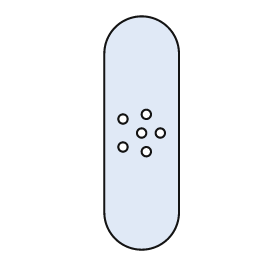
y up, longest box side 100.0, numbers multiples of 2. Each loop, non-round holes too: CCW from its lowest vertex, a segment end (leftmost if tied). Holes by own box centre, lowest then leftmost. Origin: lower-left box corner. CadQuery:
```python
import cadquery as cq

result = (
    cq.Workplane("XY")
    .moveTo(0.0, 16.0)
    .threePointArc((16.0, 0.0), (32.0, 16.0))
    .lineTo(32.0, 84.0)
    .threePointArc((16.0, 100.0), (0.0, 84.0))
    .close()
    .moveTo(18.0, 42.0)
    .circle(2.0)
    .moveTo(8.0, 44.0)
    .circle(2.0)
    .moveTo(16.0, 50.0)
    .circle(2.0)
    .moveTo(24.0, 50.0)
    .circle(2.0)
    .moveTo(8.0, 56.0)
    .circle(2.0)
    .moveTo(18.0, 58.0)
    .circle(2.0)
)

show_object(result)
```